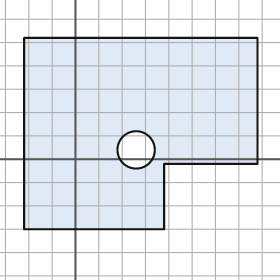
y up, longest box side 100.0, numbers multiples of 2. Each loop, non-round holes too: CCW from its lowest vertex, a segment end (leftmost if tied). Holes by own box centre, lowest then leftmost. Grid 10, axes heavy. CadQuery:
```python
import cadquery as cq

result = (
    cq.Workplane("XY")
    .moveTo(-22.0, -30.0)
    .lineTo(38.0, -30.0)
    .lineTo(38.0, -2.0)
    .lineTo(78.0, -2.0)
    .lineTo(78.0, 52.0)
    .lineTo(-22.0, 52.0)
    .close()
    .moveTo(26.0, 4.0)
    .circle(8.0)
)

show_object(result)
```